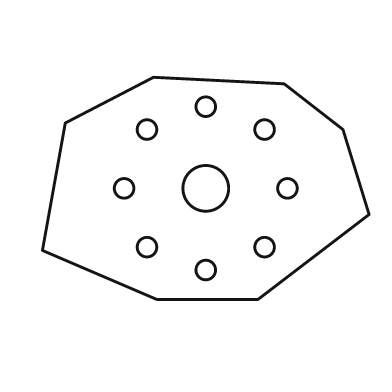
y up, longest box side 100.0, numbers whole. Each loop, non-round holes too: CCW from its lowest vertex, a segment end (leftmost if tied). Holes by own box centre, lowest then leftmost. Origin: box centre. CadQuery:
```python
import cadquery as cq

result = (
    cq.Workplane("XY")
    .moveTo(-15.0, -34.0)
    .lineTo(16.0, -34.0)
    .lineTo(50.0, -8.0)
    .lineTo(42.0, 18.0)
    .lineTo(24.0, 32.0)
    .lineTo(-16.0, 34.0)
    .lineTo(-43.0, 20.0)
    .lineTo(-50.0, -19.0)
    .close()
    .moveTo(0.0, -25.0)
    .circle(3.0)
    .moveTo(-18.0, -18.0)
    .circle(3.0)
    .moveTo(18.0, -18.0)
    .circle(3.0)
    .moveTo(-25.0, 0.0)
    .circle(3.0)
    .moveTo(0.0, 0.0)
    .circle(7.0)
    .moveTo(25.0, 0.0)
    .circle(3.0)
    .moveTo(-18.0, 18.0)
    .circle(3.0)
    .moveTo(18.0, 18.0)
    .circle(3.0)
    .moveTo(0.0, 25.0)
    .circle(3.0)
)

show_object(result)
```